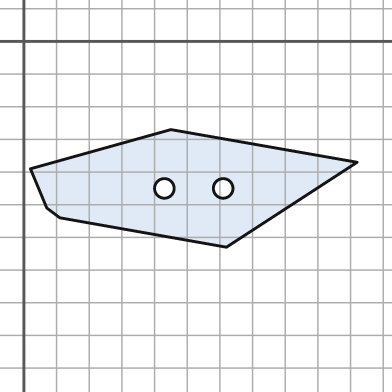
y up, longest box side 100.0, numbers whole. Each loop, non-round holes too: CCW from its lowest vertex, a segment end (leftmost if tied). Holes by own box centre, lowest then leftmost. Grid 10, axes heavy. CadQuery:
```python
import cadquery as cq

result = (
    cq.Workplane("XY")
    .moveTo(62.0, -63.0)
    .lineTo(102.0, -37.0)
    .lineTo(45.0, -27.0)
    .lineTo(2.0, -39.0)
    .lineTo(7.0, -51.0)
    .lineTo(11.0, -54.0)
    .close()
    .moveTo(43.0, -45.0)
    .circle(3.0)
    .moveTo(61.0, -45.0)
    .circle(3.0)
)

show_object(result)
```